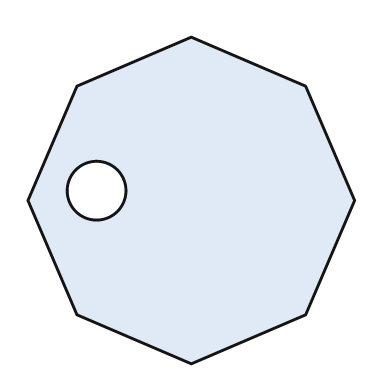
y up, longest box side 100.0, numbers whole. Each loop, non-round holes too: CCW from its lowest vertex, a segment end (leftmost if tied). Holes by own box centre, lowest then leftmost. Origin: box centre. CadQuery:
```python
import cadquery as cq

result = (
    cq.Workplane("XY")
    .moveTo(0.0, -50.0)
    .lineTo(35.0, -35.0)
    .lineTo(50.0, 0.0)
    .lineTo(35.0, 35.0)
    .lineTo(0.0, 50.0)
    .lineTo(-35.0, 35.0)
    .lineTo(-50.0, 0.0)
    .lineTo(-35.0, -35.0)
    .close()
    .moveTo(-29.0, 3.0)
    .circle(9.0)
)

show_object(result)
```